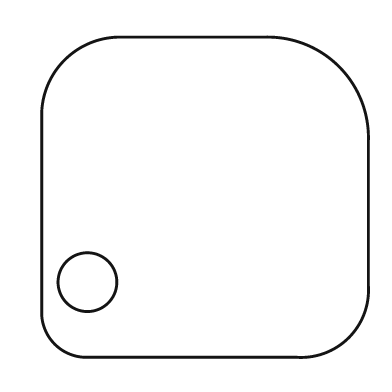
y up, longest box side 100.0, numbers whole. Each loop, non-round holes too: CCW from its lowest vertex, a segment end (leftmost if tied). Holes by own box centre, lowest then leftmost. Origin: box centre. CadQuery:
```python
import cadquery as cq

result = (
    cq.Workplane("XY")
    .moveTo(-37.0, -49.0)
    .lineTo(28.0, -49.0)
    .threePointArc((44.0, -43.0), (50.0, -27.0))
    .lineTo(50.0, 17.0)
    .threePointArc((41.0, 40.0), (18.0, 49.0))
    .lineTo(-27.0, 49.0)
    .threePointArc((-43.0, 42.0), (-50.0, 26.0))
    .lineTo(-50.0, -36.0)
    .threePointArc((-46.0, -45.0), (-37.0, -49.0))
    .close()
    .moveTo(-36.0, -26.0)
    .circle(9.0)
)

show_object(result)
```